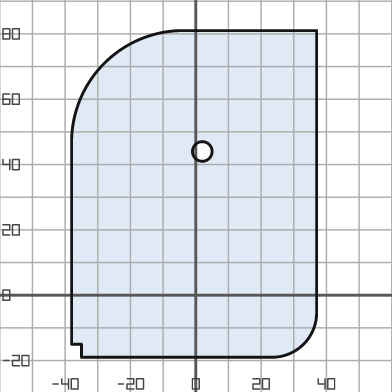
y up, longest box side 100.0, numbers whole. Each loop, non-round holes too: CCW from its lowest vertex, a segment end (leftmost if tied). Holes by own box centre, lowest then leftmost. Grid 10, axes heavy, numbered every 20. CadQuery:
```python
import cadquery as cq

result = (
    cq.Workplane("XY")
    .moveTo(-35.0, -19.0)
    .lineTo(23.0, -19.0)
    .threePointArc((33.0, -15.0), (37.0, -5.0))
    .lineTo(37.0, 81.0)
    .lineTo(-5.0, 81.0)
    .threePointArc((-28.0, 71.0), (-38.0, 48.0))
    .lineTo(-38.0, -15.0)
    .lineTo(-35.0, -15.0)
    .close()
    .moveTo(2.0, 44.0)
    .circle(3.0)
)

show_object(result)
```